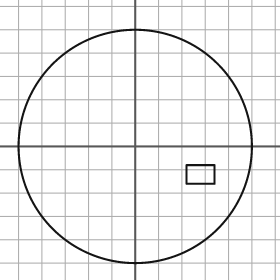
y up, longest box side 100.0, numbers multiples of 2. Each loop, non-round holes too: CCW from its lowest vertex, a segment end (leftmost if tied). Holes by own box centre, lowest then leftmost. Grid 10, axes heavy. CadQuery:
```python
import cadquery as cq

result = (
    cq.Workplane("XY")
    .moveTo(0.0, 0.0)
    .circle(50.0)
    .moveTo(22.0, -16.0)
    .lineTo(34.0, -16.0)
    .lineTo(34.0, -8.0)
    .lineTo(22.0, -8.0)
    .close()
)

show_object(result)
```